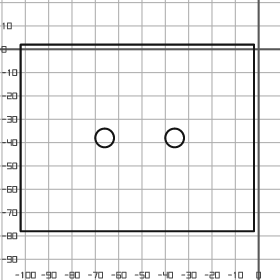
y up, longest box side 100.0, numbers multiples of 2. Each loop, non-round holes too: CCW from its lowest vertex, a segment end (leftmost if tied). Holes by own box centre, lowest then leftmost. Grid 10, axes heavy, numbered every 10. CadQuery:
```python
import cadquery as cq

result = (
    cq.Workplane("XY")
    .moveTo(-102.0, -78.0)
    .lineTo(-2.0, -78.0)
    .lineTo(-2.0, 2.0)
    .lineTo(-102.0, 2.0)
    .close()
    .moveTo(-66.0, -38.0)
    .circle(4.0)
    .moveTo(-36.0, -38.0)
    .circle(4.0)
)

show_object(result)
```